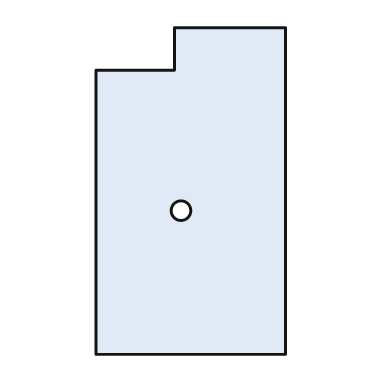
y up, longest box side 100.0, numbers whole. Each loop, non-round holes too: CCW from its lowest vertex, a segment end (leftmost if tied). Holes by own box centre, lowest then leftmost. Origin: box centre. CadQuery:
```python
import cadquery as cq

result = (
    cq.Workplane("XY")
    .moveTo(-29.0, -50.0)
    .lineTo(29.0, -50.0)
    .lineTo(29.0, 50.0)
    .lineTo(-5.0, 50.0)
    .lineTo(-5.0, 37.0)
    .lineTo(-29.0, 37.0)
    .close()
    .moveTo(-3.0, -6.0)
    .circle(3.0)
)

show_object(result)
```